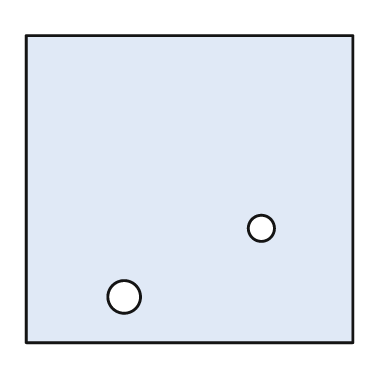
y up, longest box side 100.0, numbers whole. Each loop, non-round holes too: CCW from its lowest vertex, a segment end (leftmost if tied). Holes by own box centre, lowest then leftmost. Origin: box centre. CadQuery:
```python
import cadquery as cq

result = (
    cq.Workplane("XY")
    .moveTo(-50.0, -47.0)
    .lineTo(50.0, -47.0)
    .lineTo(50.0, 47.0)
    .lineTo(-50.0, 47.0)
    .close()
    .moveTo(-20.0, -33.0)
    .circle(5.0)
    .moveTo(22.0, -12.0)
    .circle(4.0)
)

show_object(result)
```